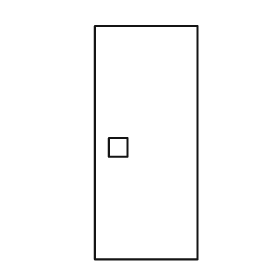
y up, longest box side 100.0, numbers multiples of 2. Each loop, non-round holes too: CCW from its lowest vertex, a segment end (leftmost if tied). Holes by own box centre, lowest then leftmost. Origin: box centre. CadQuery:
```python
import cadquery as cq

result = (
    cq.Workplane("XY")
    .moveTo(-22.0, -50.0)
    .lineTo(22.0, -50.0)
    .lineTo(22.0, 50.0)
    .lineTo(-22.0, 50.0)
    .close()
    .moveTo(-16.0, -6.0)
    .lineTo(-8.0, -6.0)
    .lineTo(-8.0, 2.0)
    .lineTo(-16.0, 2.0)
    .close()
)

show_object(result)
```